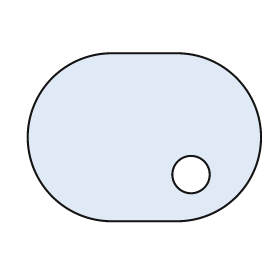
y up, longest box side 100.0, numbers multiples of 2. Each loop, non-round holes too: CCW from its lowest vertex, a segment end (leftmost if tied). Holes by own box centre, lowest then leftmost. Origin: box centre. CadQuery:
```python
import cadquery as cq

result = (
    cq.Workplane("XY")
    .moveTo(-14.0, -36.0)
    .lineTo(14.0, -36.0)
    .threePointArc((50.0, 0.0), (14.0, 36.0))
    .lineTo(-14.0, 36.0)
    .threePointArc((-50.0, 0.0), (-14.0, -36.0))
    .close()
    .moveTo(20.0, -16.0)
    .circle(8.0)
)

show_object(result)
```